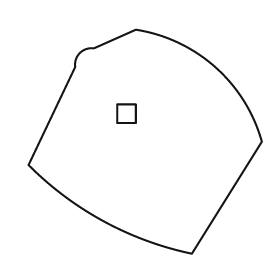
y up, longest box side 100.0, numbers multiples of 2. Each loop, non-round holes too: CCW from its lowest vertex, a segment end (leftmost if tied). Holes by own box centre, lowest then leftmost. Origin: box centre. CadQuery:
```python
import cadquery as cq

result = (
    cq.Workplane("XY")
    .moveTo(20.0, -48.0)
    .lineTo(50.0, 0.0)
    .threePointArc((30.0, 32.0), (-4.0, 48.0))
    .lineTo(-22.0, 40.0)
    .threePointArc((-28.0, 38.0), (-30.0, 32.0))
    .lineTo(-50.0, -10.0)
    .threePointArc((-18.0, -34.0), (20.0, -48.0))
    .close()
    .moveTo(-12.0, 8.0)
    .lineTo(-4.0, 8.0)
    .lineTo(-4.0, 16.0)
    .lineTo(-12.0, 16.0)
    .close()
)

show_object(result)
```